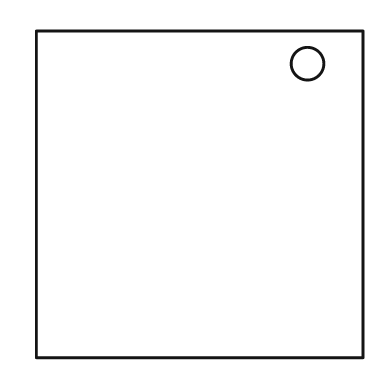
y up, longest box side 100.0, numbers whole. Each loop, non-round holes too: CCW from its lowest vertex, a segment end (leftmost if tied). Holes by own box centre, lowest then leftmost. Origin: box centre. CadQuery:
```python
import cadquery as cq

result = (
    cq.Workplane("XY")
    .moveTo(-50.0, -50.0)
    .lineTo(50.0, -50.0)
    .lineTo(50.0, 50.0)
    .lineTo(-50.0, 50.0)
    .close()
    .moveTo(33.0, 40.0)
    .circle(5.0)
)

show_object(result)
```